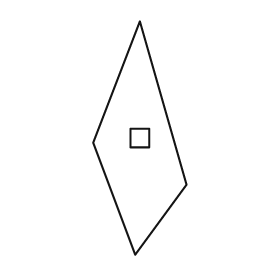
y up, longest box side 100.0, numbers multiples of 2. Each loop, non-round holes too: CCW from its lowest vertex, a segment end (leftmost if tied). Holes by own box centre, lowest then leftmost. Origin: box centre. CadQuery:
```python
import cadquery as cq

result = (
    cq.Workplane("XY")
    .moveTo(-2.0, -50.0)
    .lineTo(20.0, -20.0)
    .lineTo(0.0, 50.0)
    .lineTo(-20.0, -2.0)
    .close()
    .moveTo(-4.0, -4.0)
    .lineTo(4.0, -4.0)
    .lineTo(4.0, 4.0)
    .lineTo(-4.0, 4.0)
    .close()
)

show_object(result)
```